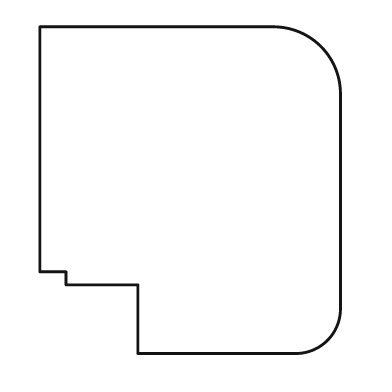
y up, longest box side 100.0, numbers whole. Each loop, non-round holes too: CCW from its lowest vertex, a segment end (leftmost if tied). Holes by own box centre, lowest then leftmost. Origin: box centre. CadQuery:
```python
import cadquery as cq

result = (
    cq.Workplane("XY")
    .moveTo(-16.0, -50.0)
    .lineTo(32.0, -50.0)
    .threePointArc((42.0, -46.0), (46.0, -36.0))
    .lineTo(46.0, 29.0)
    .threePointArc((40.0, 44.0), (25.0, 50.0))
    .lineTo(-46.0, 50.0)
    .lineTo(-46.0, -25.0)
    .lineTo(-38.0, -25.0)
    .lineTo(-38.0, -29.0)
    .lineTo(-16.0, -29.0)
    .close()
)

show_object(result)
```